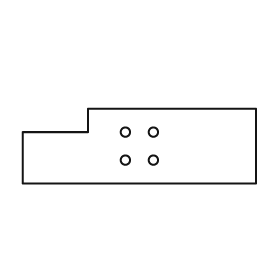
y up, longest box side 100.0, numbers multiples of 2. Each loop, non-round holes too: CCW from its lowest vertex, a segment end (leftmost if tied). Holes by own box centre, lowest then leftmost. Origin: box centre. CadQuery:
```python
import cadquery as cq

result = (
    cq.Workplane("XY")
    .moveTo(-50.0, -16.0)
    .lineTo(50.0, -16.0)
    .lineTo(50.0, 16.0)
    .lineTo(-22.0, 16.0)
    .lineTo(-22.0, 6.0)
    .lineTo(-50.0, 6.0)
    .close()
    .moveTo(-6.0, -6.0)
    .circle(2.0)
    .moveTo(6.0, -6.0)
    .circle(2.0)
    .moveTo(-6.0, 6.0)
    .circle(2.0)
    .moveTo(6.0, 6.0)
    .circle(2.0)
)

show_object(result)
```